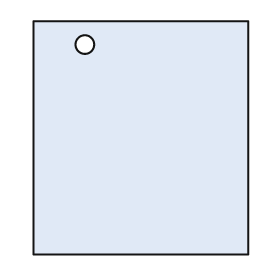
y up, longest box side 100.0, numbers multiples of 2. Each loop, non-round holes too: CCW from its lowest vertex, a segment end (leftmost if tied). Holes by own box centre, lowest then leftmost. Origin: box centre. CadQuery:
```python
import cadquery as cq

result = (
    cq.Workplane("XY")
    .moveTo(-46.0, -50.0)
    .lineTo(46.0, -50.0)
    .lineTo(46.0, 50.0)
    .lineTo(-46.0, 50.0)
    .close()
    .moveTo(-24.0, 40.0)
    .circle(4.0)
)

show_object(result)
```